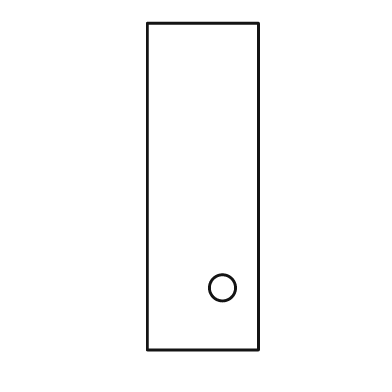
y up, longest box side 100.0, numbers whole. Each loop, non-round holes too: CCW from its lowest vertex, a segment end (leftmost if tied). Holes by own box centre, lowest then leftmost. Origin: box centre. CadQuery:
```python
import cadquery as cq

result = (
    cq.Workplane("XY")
    .moveTo(-17.0, -50.0)
    .lineTo(17.0, -50.0)
    .lineTo(17.0, 50.0)
    .lineTo(-17.0, 50.0)
    .close()
    .moveTo(6.0, -31.0)
    .circle(4.0)
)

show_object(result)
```